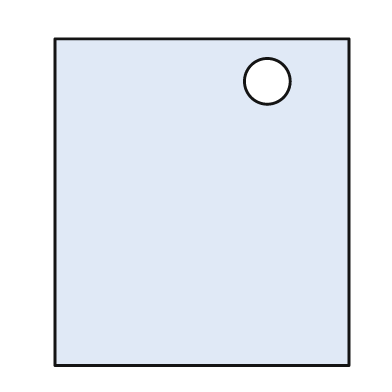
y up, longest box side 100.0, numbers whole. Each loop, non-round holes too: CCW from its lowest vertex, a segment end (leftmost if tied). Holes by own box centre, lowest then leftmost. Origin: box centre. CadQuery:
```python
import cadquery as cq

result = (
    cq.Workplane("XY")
    .moveTo(-45.0, -50.0)
    .lineTo(45.0, -50.0)
    .lineTo(45.0, 50.0)
    .lineTo(-45.0, 50.0)
    .close()
    .moveTo(20.0, 37.0)
    .circle(7.0)
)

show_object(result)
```